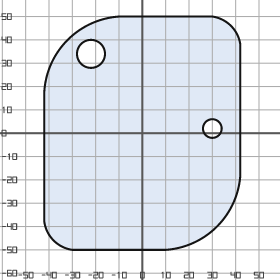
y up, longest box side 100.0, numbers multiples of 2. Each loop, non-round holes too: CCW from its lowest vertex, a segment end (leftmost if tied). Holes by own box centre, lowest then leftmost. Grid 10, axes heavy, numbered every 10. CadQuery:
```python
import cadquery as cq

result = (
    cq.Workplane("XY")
    .moveTo(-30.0, -50.0)
    .lineTo(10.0, -50.0)
    .threePointArc((32.0, -40.0), (42.0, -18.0))
    .lineTo(42.0, 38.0)
    .threePointArc((38.0, 46.0), (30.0, 50.0))
    .lineTo(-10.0, 50.0)
    .threePointArc((-32.0, 40.0), (-42.0, 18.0))
    .lineTo(-42.0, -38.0)
    .threePointArc((-38.0, -46.0), (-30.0, -50.0))
    .close()
    .moveTo(30.0, 2.0)
    .circle(4.0)
    .moveTo(-22.0, 34.0)
    .circle(6.0)
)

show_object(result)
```